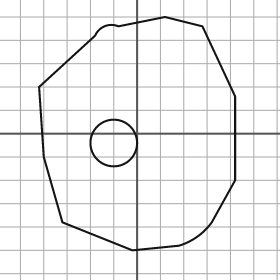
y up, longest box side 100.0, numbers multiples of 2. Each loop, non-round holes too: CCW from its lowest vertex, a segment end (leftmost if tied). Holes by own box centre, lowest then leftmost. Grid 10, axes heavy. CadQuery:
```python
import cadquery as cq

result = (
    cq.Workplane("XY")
    .moveTo(-2.0, -50.0)
    .lineTo(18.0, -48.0)
    .threePointArc((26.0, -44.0), (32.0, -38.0))
    .lineTo(42.0, -20.0)
    .lineTo(42.0, 16.0)
    .lineTo(28.0, 46.0)
    .lineTo(12.0, 50.0)
    .lineTo(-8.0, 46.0)
    .threePointArc((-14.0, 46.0), (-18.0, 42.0))
    .lineTo(-42.0, 20.0)
    .lineTo(-40.0, -10.0)
    .lineTo(-32.0, -38.0)
    .close()
    .moveTo(-10.0, -4.0)
    .circle(10.0)
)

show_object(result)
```